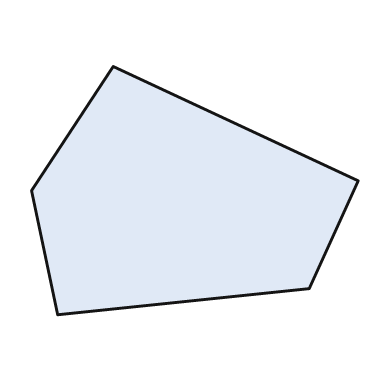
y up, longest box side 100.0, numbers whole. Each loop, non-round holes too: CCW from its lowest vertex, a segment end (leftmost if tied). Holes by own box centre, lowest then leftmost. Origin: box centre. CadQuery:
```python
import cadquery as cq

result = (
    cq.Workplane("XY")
    .moveTo(-42.0, -38.0)
    .lineTo(35.0, -30.0)
    .lineTo(50.0, 3.0)
    .lineTo(-25.0, 38.0)
    .lineTo(-50.0, 0.0)
    .close()
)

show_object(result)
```